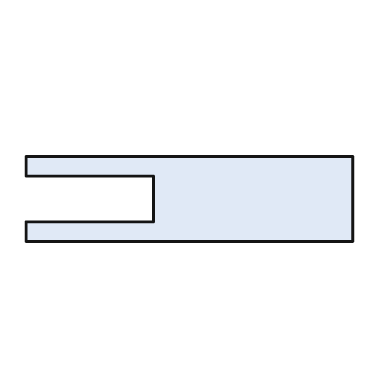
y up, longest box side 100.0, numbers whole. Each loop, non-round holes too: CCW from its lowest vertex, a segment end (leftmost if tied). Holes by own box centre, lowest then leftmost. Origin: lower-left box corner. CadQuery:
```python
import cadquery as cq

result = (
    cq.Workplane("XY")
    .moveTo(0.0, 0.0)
    .lineTo(100.0, 0.0)
    .lineTo(100.0, 26.0)
    .lineTo(0.0, 26.0)
    .lineTo(0.0, 20.0)
    .lineTo(39.0, 20.0)
    .lineTo(39.0, 6.0)
    .lineTo(0.0, 6.0)
    .close()
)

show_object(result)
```